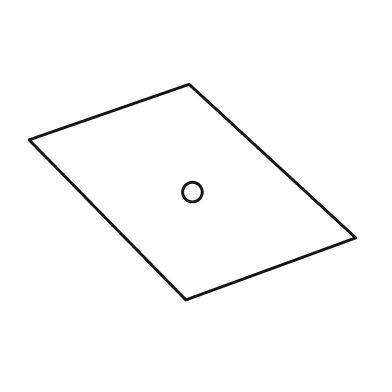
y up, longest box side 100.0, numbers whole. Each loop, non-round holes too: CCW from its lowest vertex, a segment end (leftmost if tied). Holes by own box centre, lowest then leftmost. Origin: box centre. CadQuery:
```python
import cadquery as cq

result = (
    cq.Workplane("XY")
    .moveTo(-2.0, -33.0)
    .lineTo(50.0, -14.0)
    .lineTo(-1.0, 33.0)
    .lineTo(-50.0, 16.0)
    .close()
    .moveTo(0.0, 0.0)
    .circle(3.0)
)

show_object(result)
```